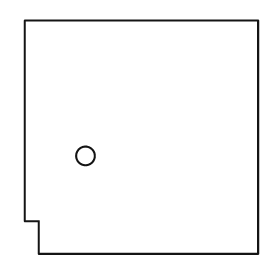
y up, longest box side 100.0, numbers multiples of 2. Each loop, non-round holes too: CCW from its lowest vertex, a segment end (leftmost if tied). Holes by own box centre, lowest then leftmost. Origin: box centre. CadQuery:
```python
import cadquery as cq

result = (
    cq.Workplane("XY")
    .moveTo(-44.0, -50.0)
    .lineTo(50.0, -50.0)
    .lineTo(50.0, 50.0)
    .lineTo(-50.0, 50.0)
    .lineTo(-50.0, -36.0)
    .lineTo(-44.0, -36.0)
    .close()
    .moveTo(-24.0, -8.0)
    .circle(4.0)
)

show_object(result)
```